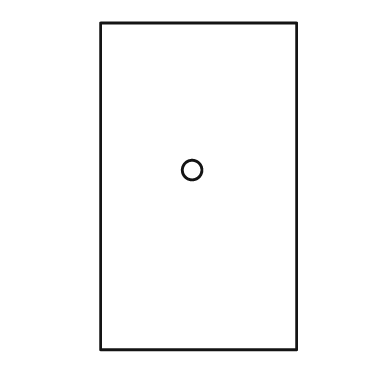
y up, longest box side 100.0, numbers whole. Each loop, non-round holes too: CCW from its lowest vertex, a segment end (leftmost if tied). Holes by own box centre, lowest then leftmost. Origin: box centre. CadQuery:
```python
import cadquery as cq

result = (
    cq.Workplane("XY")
    .moveTo(-30.0, -50.0)
    .lineTo(30.0, -50.0)
    .lineTo(30.0, 50.0)
    .lineTo(-30.0, 50.0)
    .close()
    .moveTo(-2.0, 5.0)
    .circle(3.0)
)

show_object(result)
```